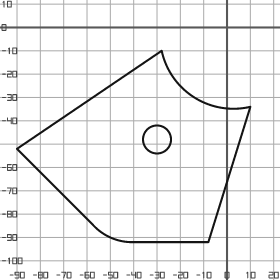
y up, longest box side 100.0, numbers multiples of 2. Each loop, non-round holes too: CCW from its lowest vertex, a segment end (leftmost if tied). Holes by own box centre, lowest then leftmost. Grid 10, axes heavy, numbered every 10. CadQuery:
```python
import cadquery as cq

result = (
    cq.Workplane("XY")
    .moveTo(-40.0, -92.0)
    .lineTo(-8.0, -92.0)
    .lineTo(10.0, -34.0)
    .threePointArc((-14.0, -30.0), (-28.0, -10.0))
    .lineTo(-90.0, -52.0)
    .lineTo(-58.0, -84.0)
    .threePointArc((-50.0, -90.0), (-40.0, -92.0))
    .close()
    .moveTo(-30.0, -48.0)
    .circle(6.0)
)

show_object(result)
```